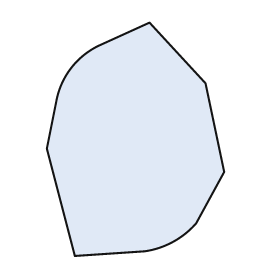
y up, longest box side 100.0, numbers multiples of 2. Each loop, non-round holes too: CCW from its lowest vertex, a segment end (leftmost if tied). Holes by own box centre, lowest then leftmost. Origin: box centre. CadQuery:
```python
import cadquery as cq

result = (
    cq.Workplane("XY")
    .moveTo(-26.0, -50.0)
    .lineTo(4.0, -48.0)
    .threePointArc((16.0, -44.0), (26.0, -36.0))
    .lineTo(38.0, -14.0)
    .lineTo(30.0, 24.0)
    .lineTo(6.0, 50.0)
    .lineTo(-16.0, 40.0)
    .threePointArc((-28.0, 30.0), (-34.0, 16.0))
    .lineTo(-38.0, -4.0)
    .close()
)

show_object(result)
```